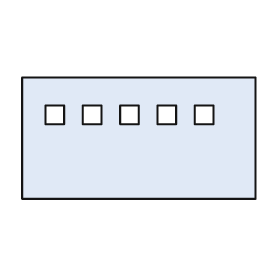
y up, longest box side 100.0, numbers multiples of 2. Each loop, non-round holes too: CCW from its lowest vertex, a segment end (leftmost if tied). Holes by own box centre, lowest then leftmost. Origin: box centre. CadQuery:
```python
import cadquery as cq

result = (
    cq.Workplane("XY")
    .moveTo(-50.0, -26.0)
    .lineTo(50.0, -26.0)
    .lineTo(50.0, 26.0)
    .lineTo(-50.0, 26.0)
    .close()
    .moveTo(-40.0, 6.0)
    .lineTo(-32.0, 6.0)
    .lineTo(-32.0, 14.0)
    .lineTo(-40.0, 14.0)
    .close()
    .moveTo(-24.0, 6.0)
    .lineTo(-16.0, 6.0)
    .lineTo(-16.0, 14.0)
    .lineTo(-24.0, 14.0)
    .close()
    .moveTo(-8.0, 6.0)
    .lineTo(0.0, 6.0)
    .lineTo(0.0, 14.0)
    .lineTo(-8.0, 14.0)
    .close()
    .moveTo(8.0, 6.0)
    .lineTo(16.0, 6.0)
    .lineTo(16.0, 14.0)
    .lineTo(8.0, 14.0)
    .close()
    .moveTo(24.0, 6.0)
    .lineTo(32.0, 6.0)
    .lineTo(32.0, 14.0)
    .lineTo(24.0, 14.0)
    .close()
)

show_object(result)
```